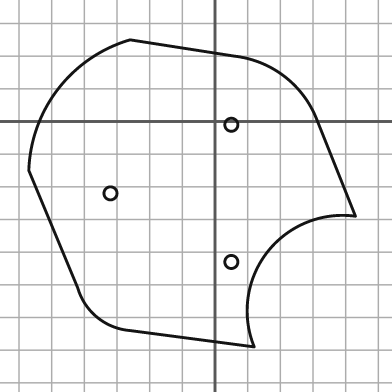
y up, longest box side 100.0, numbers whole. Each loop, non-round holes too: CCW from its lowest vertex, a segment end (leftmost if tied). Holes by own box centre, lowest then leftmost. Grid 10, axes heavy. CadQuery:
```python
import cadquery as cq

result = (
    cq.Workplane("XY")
    .moveTo(12.0, -69.0)
    .threePointArc((16.0, -40.0), (43.0, -29.0))
    .lineTo(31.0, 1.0)
    .threePointArc((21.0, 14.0), (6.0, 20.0))
    .lineTo(-26.0, 25.0)
    .threePointArc((-48.0, 10.0), (-57.0, -15.0))
    .lineTo(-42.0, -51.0)
    .threePointArc((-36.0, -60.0), (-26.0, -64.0))
    .close()
    .moveTo(5.0, -43.0)
    .circle(2.0)
    .moveTo(-32.0, -22.0)
    .circle(2.0)
    .moveTo(5.0, -1.0)
    .circle(2.0)
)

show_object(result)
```